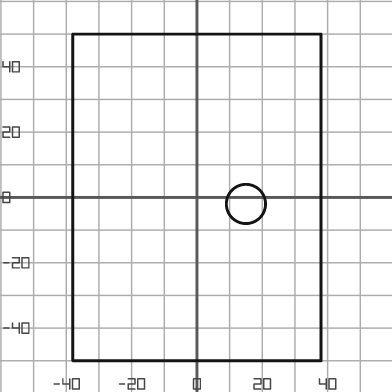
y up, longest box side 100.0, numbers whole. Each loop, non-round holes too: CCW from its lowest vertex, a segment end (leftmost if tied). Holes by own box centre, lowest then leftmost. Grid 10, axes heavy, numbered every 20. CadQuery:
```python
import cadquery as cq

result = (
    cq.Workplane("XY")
    .moveTo(-38.0, -50.0)
    .lineTo(38.0, -50.0)
    .lineTo(38.0, 50.0)
    .lineTo(-38.0, 50.0)
    .close()
    .moveTo(15.0, -2.0)
    .circle(6.0)
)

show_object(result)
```